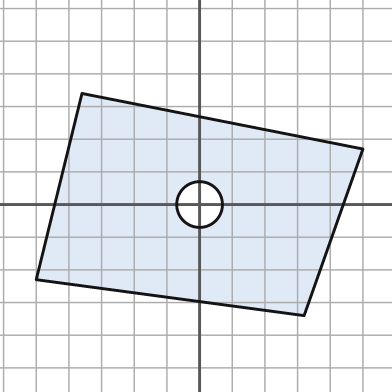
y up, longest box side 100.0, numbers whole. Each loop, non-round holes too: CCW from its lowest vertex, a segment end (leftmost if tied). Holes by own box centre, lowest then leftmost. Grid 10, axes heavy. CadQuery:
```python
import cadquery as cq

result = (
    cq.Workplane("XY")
    .moveTo(32.0, -34.0)
    .lineTo(50.0, 17.0)
    .lineTo(-36.0, 34.0)
    .lineTo(-50.0, -23.0)
    .close()
    .moveTo(0.0, 0.0)
    .circle(7.0)
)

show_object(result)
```